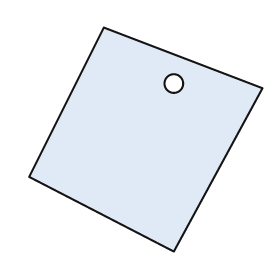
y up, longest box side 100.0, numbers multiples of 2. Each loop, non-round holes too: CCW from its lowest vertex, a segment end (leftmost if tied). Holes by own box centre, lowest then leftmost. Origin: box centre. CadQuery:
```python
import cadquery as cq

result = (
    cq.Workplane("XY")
    .moveTo(12.0, -48.0)
    .lineTo(50.0, 22.0)
    .lineTo(-18.0, 48.0)
    .lineTo(-50.0, -16.0)
    .close()
    .moveTo(12.0, 24.0)
    .circle(4.0)
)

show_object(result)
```